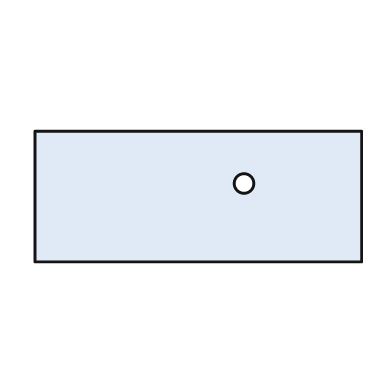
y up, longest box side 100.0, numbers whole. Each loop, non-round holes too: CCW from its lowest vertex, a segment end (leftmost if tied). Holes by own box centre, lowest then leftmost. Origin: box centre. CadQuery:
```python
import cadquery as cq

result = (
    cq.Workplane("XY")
    .moveTo(-50.0, -20.0)
    .lineTo(50.0, -20.0)
    .lineTo(50.0, 20.0)
    .lineTo(-50.0, 20.0)
    .close()
    .moveTo(14.0, 4.0)
    .circle(3.0)
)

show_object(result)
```